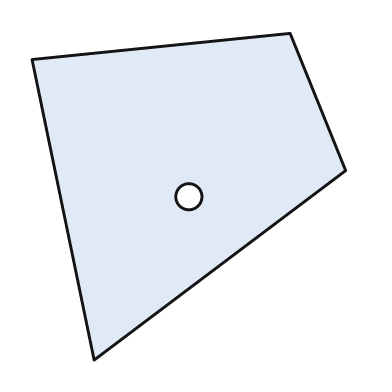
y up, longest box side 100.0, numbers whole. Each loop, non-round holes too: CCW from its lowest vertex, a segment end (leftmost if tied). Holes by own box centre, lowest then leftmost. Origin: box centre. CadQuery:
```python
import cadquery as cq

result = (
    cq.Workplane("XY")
    .moveTo(-29.0, -50.0)
    .lineTo(48.0, 8.0)
    .lineTo(31.0, 50.0)
    .lineTo(-48.0, 42.0)
    .close()
    .moveTo(0.0, 0.0)
    .circle(4.0)
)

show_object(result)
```